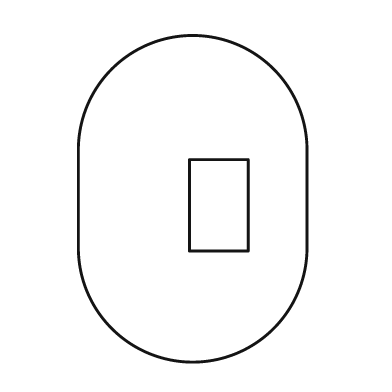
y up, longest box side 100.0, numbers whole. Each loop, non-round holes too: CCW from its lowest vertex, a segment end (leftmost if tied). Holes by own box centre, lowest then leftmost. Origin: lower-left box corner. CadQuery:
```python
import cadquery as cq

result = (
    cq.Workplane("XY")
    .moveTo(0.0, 35.0)
    .threePointArc((35.0, 0.0), (70.0, 35.0))
    .lineTo(70.0, 65.0)
    .threePointArc((35.0, 100.0), (0.0, 65.0))
    .close()
    .moveTo(34.0, 34.0)
    .lineTo(52.0, 34.0)
    .lineTo(52.0, 62.0)
    .lineTo(34.0, 62.0)
    .close()
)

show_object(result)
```